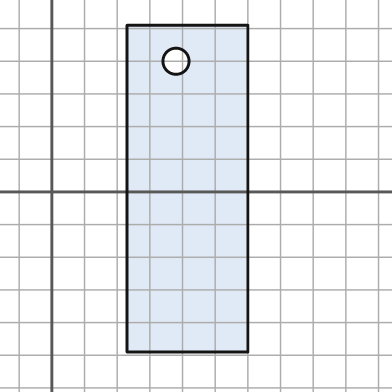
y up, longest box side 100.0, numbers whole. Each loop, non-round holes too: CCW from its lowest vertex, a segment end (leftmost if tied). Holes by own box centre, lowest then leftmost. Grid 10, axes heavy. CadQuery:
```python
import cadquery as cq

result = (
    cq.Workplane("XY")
    .moveTo(23.0, -49.0)
    .lineTo(60.0, -49.0)
    .lineTo(60.0, 51.0)
    .lineTo(23.0, 51.0)
    .close()
    .moveTo(38.0, 40.0)
    .circle(4.0)
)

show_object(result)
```